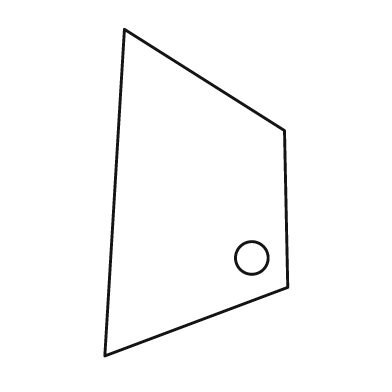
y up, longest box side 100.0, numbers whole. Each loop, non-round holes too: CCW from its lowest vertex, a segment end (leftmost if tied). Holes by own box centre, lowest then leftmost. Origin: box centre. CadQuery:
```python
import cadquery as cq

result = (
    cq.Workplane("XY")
    .moveTo(-28.0, -50.0)
    .lineTo(28.0, -29.0)
    .lineTo(27.0, 19.0)
    .lineTo(-22.0, 50.0)
    .close()
    .moveTo(17.0, -20.0)
    .circle(5.0)
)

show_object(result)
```